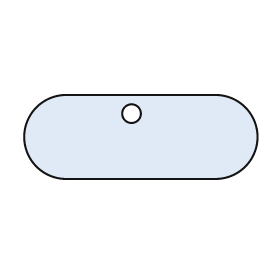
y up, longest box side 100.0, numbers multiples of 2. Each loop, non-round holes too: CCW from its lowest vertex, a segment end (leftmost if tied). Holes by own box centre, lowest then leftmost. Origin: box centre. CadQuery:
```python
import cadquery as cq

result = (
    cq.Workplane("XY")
    .moveTo(-32.0, -18.0)
    .lineTo(32.0, -18.0)
    .threePointArc((50.0, 0.0), (32.0, 18.0))
    .lineTo(-32.0, 18.0)
    .threePointArc((-50.0, 0.0), (-32.0, -18.0))
    .close()
    .moveTo(-4.0, 10.0)
    .circle(4.0)
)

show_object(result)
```